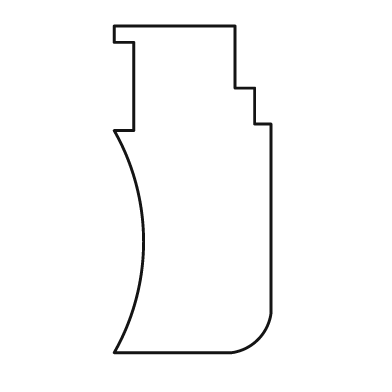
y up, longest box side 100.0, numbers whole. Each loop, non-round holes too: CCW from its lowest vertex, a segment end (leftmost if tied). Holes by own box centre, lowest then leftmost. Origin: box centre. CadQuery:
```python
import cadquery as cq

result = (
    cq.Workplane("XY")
    .moveTo(-24.0, -50.0)
    .lineTo(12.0, -50.0)
    .threePointArc((20.0, -46.0), (24.0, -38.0))
    .lineTo(24.0, 20.0)
    .lineTo(19.0, 20.0)
    .lineTo(19.0, 31.0)
    .lineTo(13.0, 31.0)
    .lineTo(13.0, 50.0)
    .lineTo(-24.0, 50.0)
    .lineTo(-24.0, 45.0)
    .lineTo(-18.0, 45.0)
    .lineTo(-18.0, 18.0)
    .lineTo(-24.0, 18.0)
    .threePointArc((-15.0, -16.0), (-24.0, -50.0))
    .close()
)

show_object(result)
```